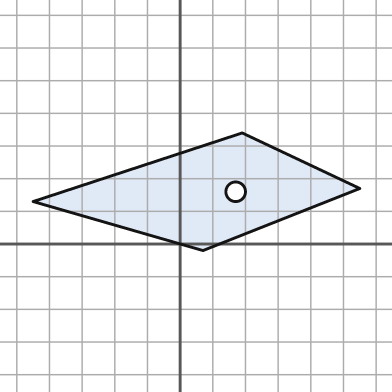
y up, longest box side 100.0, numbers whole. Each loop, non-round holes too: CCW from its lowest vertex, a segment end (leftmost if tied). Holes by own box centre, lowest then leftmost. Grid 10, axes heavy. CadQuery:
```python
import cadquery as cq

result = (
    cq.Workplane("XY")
    .moveTo(7.0, -2.0)
    .lineTo(55.0, 17.0)
    .lineTo(19.0, 34.0)
    .lineTo(-45.0, 13.0)
    .close()
    .moveTo(17.0, 16.0)
    .circle(3.0)
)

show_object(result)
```